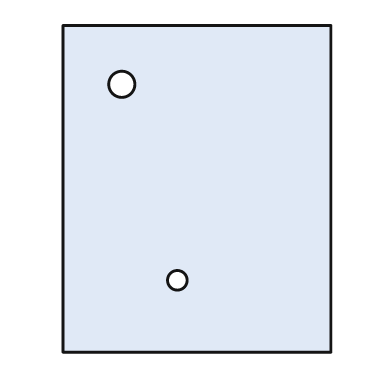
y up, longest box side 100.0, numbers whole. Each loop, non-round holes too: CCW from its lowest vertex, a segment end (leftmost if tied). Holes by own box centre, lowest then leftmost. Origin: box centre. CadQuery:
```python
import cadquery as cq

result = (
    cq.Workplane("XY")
    .moveTo(-41.0, -50.0)
    .lineTo(41.0, -50.0)
    .lineTo(41.0, 50.0)
    .lineTo(-41.0, 50.0)
    .close()
    .moveTo(-6.0, -28.0)
    .circle(3.0)
    .moveTo(-23.0, 32.0)
    .circle(4.0)
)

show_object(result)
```